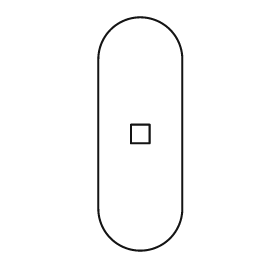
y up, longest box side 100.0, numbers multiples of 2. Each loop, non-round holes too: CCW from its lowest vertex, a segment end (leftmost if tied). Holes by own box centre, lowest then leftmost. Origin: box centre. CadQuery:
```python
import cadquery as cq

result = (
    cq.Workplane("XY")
    .moveTo(-18.0, -32.0)
    .threePointArc((0.0, -50.0), (18.0, -32.0))
    .lineTo(18.0, 32.0)
    .threePointArc((0.0, 50.0), (-18.0, 32.0))
    .close()
    .moveTo(-4.0, -4.0)
    .lineTo(4.0, -4.0)
    .lineTo(4.0, 4.0)
    .lineTo(-4.0, 4.0)
    .close()
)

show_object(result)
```